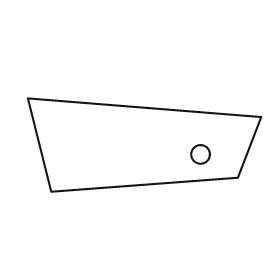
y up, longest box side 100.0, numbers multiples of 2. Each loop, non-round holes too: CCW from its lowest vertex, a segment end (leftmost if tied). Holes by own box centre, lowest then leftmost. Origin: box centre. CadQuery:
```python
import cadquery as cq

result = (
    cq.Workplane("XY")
    .moveTo(-40.0, -20.0)
    .lineTo(40.0, -14.0)
    .lineTo(50.0, 12.0)
    .lineTo(-50.0, 20.0)
    .close()
    .moveTo(24.0, -4.0)
    .circle(4.0)
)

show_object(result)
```